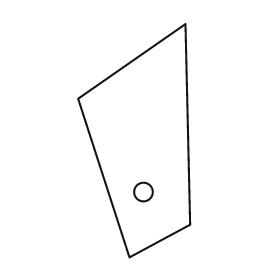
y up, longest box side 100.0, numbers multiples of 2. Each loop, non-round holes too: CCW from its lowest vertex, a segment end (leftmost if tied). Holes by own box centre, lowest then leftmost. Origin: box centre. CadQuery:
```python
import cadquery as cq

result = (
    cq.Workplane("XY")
    .moveTo(-2.0, -50.0)
    .lineTo(24.0, -36.0)
    .lineTo(22.0, 50.0)
    .lineTo(-24.0, 18.0)
    .close()
    .moveTo(4.0, -22.0)
    .circle(4.0)
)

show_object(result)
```